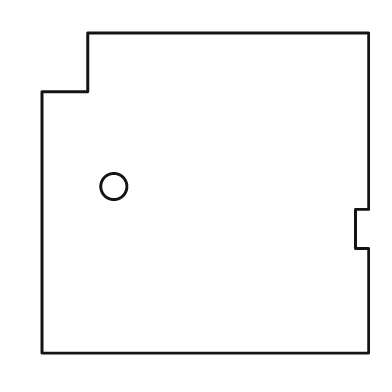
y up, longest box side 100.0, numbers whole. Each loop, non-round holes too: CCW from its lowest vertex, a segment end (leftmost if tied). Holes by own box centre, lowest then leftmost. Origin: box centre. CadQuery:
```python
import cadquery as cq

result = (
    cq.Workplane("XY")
    .moveTo(-50.0, -49.0)
    .lineTo(50.0, -49.0)
    .lineTo(50.0, -17.0)
    .lineTo(46.0, -17.0)
    .lineTo(46.0, -5.0)
    .lineTo(50.0, -5.0)
    .lineTo(50.0, 49.0)
    .lineTo(-36.0, 49.0)
    .lineTo(-36.0, 31.0)
    .lineTo(-50.0, 31.0)
    .close()
    .moveTo(-28.0, 2.0)
    .circle(4.0)
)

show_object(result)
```